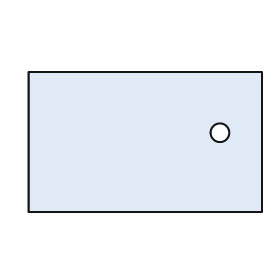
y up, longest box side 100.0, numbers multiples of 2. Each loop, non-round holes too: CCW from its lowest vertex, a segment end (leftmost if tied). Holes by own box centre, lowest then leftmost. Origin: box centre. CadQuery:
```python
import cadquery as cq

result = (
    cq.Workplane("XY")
    .moveTo(-50.0, -30.0)
    .lineTo(50.0, -30.0)
    .lineTo(50.0, 30.0)
    .lineTo(-50.0, 30.0)
    .close()
    .moveTo(32.0, 4.0)
    .circle(4.0)
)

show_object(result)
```